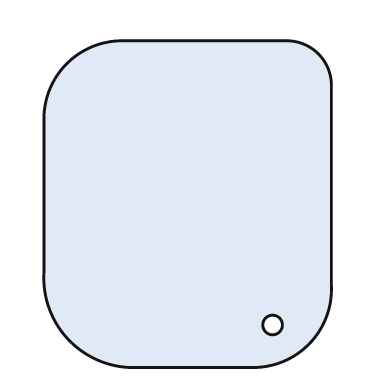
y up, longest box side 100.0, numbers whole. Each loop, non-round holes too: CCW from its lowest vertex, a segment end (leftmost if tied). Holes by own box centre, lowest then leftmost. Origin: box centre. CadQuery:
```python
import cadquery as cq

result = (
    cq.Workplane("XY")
    .moveTo(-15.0, -50.0)
    .lineTo(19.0, -50.0)
    .threePointArc((37.0, -43.0), (44.0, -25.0))
    .lineTo(44.0, 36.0)
    .threePointArc((40.0, 46.0), (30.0, 50.0))
    .lineTo(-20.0, 50.0)
    .threePointArc((-37.0, 43.0), (-44.0, 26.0))
    .lineTo(-44.0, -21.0)
    .threePointArc((-36.0, -42.0), (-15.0, -50.0))
    .close()
    .moveTo(26.0, -37.0)
    .circle(3.0)
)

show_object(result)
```